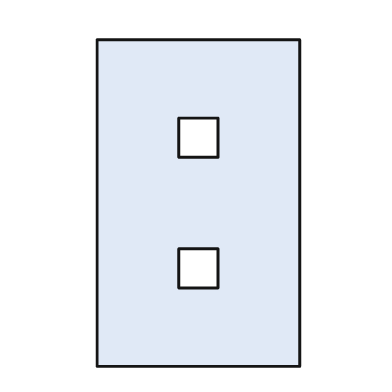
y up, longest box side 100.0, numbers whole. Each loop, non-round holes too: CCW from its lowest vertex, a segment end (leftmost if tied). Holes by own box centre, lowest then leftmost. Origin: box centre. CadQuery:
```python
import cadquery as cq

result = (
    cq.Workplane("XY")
    .moveTo(-31.0, -50.0)
    .lineTo(31.0, -50.0)
    .lineTo(31.0, 50.0)
    .lineTo(-31.0, 50.0)
    .close()
    .moveTo(-6.0, -26.0)
    .lineTo(6.0, -26.0)
    .lineTo(6.0, -14.0)
    .lineTo(-6.0, -14.0)
    .close()
    .moveTo(-6.0, 14.0)
    .lineTo(6.0, 14.0)
    .lineTo(6.0, 26.0)
    .lineTo(-6.0, 26.0)
    .close()
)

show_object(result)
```